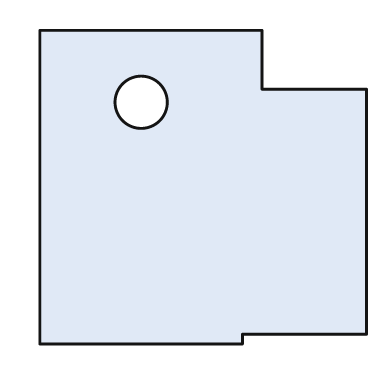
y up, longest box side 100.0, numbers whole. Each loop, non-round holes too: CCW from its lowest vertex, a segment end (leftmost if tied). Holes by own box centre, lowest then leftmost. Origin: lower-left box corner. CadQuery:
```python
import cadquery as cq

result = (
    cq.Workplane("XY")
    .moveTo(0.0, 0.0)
    .lineTo(62.0, 0.0)
    .lineTo(62.0, 3.0)
    .lineTo(100.0, 3.0)
    .lineTo(100.0, 78.0)
    .lineTo(68.0, 78.0)
    .lineTo(68.0, 96.0)
    .lineTo(0.0, 96.0)
    .close()
    .moveTo(31.0, 74.0)
    .circle(8.0)
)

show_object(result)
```